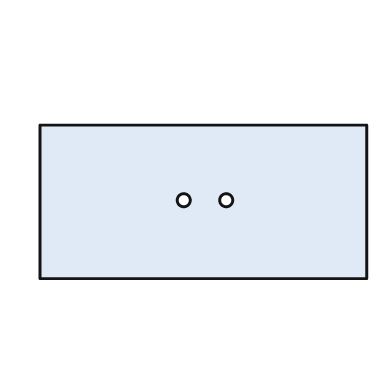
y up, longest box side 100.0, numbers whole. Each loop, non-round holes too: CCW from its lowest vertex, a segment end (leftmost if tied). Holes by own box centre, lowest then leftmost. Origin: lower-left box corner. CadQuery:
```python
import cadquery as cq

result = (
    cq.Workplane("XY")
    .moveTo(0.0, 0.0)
    .lineTo(100.0, 0.0)
    .lineTo(100.0, 47.0)
    .lineTo(0.0, 47.0)
    .close()
    .moveTo(44.0, 24.0)
    .circle(2.0)
    .moveTo(57.0, 24.0)
    .circle(2.0)
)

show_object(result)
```